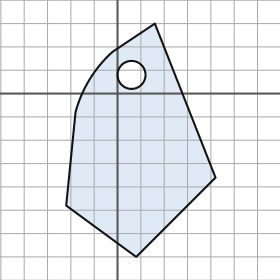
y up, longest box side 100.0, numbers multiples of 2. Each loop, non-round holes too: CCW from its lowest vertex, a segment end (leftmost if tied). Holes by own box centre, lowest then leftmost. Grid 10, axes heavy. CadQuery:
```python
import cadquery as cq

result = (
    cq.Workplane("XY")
    .moveTo(8.0, -70.0)
    .lineTo(42.0, -36.0)
    .lineTo(16.0, 30.0)
    .lineTo(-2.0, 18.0)
    .threePointArc((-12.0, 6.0), (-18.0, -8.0))
    .lineTo(-22.0, -48.0)
    .close()
    .moveTo(6.0, 8.0)
    .circle(6.0)
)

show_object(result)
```